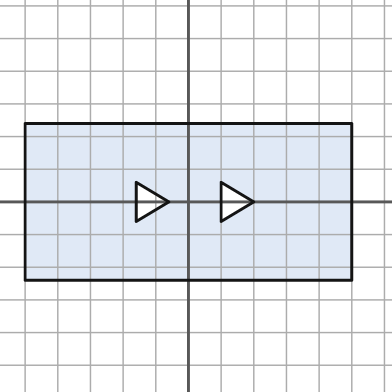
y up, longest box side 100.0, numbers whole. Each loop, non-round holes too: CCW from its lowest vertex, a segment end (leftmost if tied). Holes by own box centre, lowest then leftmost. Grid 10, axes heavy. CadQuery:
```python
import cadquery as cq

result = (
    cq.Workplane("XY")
    .moveTo(-50.0, -24.0)
    .lineTo(50.0, -24.0)
    .lineTo(50.0, 24.0)
    .lineTo(-50.0, 24.0)
    .close()
    .moveTo(-16.0, -6.0)
    .lineTo(-6.0, 0.0)
    .lineTo(-16.0, 6.0)
    .close()
    .moveTo(10.0, -6.0)
    .lineTo(20.0, 0.0)
    .lineTo(10.0, 6.0)
    .close()
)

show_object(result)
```